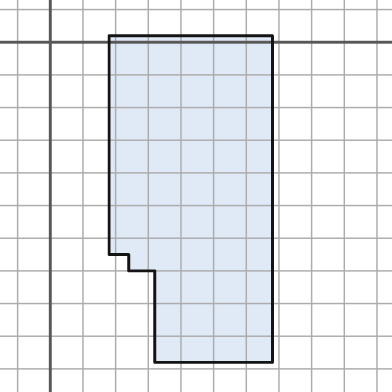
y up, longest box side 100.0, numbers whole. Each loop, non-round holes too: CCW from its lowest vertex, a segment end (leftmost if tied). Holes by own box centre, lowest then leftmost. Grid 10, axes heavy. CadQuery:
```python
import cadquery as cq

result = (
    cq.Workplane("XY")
    .moveTo(32.0, -98.0)
    .lineTo(68.0, -98.0)
    .lineTo(68.0, 2.0)
    .lineTo(18.0, 2.0)
    .lineTo(18.0, -65.0)
    .lineTo(24.0, -65.0)
    .lineTo(24.0, -70.0)
    .lineTo(32.0, -70.0)
    .close()
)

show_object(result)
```